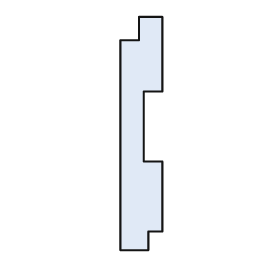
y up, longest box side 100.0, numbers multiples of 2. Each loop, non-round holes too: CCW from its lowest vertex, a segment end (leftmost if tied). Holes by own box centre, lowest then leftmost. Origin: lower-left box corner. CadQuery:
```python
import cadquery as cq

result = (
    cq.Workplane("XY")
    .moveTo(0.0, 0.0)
    .lineTo(12.0, 0.0)
    .lineTo(12.0, 8.0)
    .lineTo(18.0, 8.0)
    .lineTo(18.0, 38.0)
    .lineTo(10.0, 38.0)
    .lineTo(10.0, 68.0)
    .lineTo(18.0, 68.0)
    .lineTo(18.0, 100.0)
    .lineTo(8.0, 100.0)
    .lineTo(8.0, 90.0)
    .lineTo(0.0, 90.0)
    .close()
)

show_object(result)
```